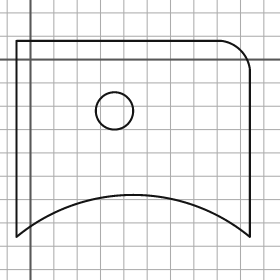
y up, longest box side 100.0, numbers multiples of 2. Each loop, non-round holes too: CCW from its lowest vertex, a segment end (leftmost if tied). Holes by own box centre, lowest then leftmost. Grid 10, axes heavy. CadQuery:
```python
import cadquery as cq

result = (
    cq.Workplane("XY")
    .moveTo(-6.0, -76.0)
    .threePointArc((44.0, -58.0), (94.0, -76.0))
    .lineTo(94.0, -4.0)
    .threePointArc((90.0, 4.0), (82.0, 8.0))
    .lineTo(-6.0, 8.0)
    .close()
    .moveTo(36.0, -22.0)
    .circle(8.0)
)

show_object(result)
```